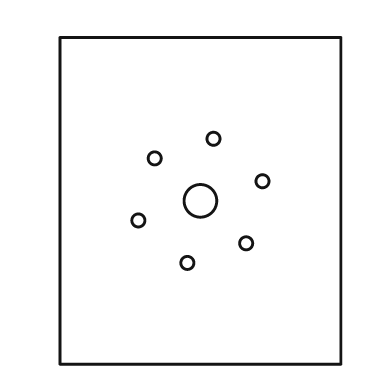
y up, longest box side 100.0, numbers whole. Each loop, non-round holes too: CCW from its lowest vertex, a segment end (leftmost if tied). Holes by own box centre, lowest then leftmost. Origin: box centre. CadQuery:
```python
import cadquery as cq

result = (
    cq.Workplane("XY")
    .moveTo(-43.0, -50.0)
    .lineTo(43.0, -50.0)
    .lineTo(43.0, 50.0)
    .lineTo(-43.0, 50.0)
    .close()
    .moveTo(-4.0, -19.0)
    .circle(2.0)
    .moveTo(14.0, -13.0)
    .circle(2.0)
    .moveTo(-19.0, -6.0)
    .circle(2.0)
    .moveTo(0.0, 0.0)
    .circle(5.0)
    .moveTo(19.0, 6.0)
    .circle(2.0)
    .moveTo(-14.0, 13.0)
    .circle(2.0)
    .moveTo(4.0, 19.0)
    .circle(2.0)
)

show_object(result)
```